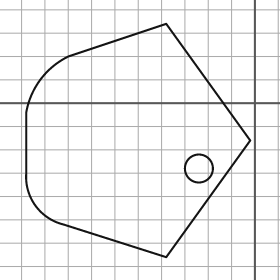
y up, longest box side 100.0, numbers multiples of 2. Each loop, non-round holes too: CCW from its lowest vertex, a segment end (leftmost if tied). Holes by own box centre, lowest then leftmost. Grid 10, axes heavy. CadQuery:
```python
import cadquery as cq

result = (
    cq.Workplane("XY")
    .moveTo(-38.0, -66.0)
    .lineTo(-2.0, -16.0)
    .lineTo(-38.0, 34.0)
    .lineTo(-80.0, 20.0)
    .threePointArc((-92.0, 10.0), (-98.0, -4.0))
    .lineTo(-98.0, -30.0)
    .threePointArc((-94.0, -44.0), (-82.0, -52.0))
    .close()
    .moveTo(-24.0, -28.0)
    .circle(6.0)
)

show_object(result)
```